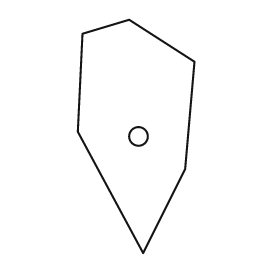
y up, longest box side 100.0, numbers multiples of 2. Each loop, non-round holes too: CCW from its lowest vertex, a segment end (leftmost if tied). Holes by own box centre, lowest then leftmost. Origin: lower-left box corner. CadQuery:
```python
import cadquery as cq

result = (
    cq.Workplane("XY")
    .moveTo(28.0, 0.0)
    .lineTo(46.0, 36.0)
    .lineTo(50.0, 82.0)
    .lineTo(22.0, 100.0)
    .lineTo(2.0, 94.0)
    .lineTo(0.0, 52.0)
    .close()
    .moveTo(26.0, 50.0)
    .circle(4.0)
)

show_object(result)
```